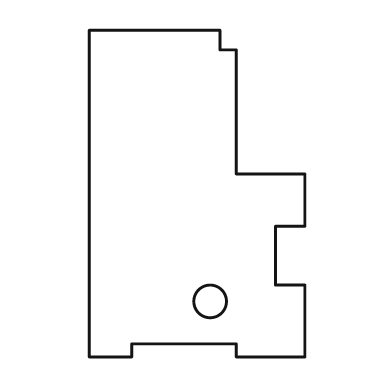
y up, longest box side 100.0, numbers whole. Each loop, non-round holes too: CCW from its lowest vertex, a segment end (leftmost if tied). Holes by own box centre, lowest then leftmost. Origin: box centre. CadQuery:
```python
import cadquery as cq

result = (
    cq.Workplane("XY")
    .moveTo(-33.0, -50.0)
    .lineTo(-20.0, -50.0)
    .lineTo(-20.0, -46.0)
    .lineTo(12.0, -46.0)
    .lineTo(12.0, -50.0)
    .lineTo(33.0, -50.0)
    .lineTo(33.0, -28.0)
    .lineTo(24.0, -28.0)
    .lineTo(24.0, -10.0)
    .lineTo(33.0, -10.0)
    .lineTo(33.0, 6.0)
    .lineTo(12.0, 6.0)
    .lineTo(12.0, 44.0)
    .lineTo(7.0, 44.0)
    .lineTo(7.0, 50.0)
    .lineTo(-33.0, 50.0)
    .close()
    .moveTo(4.0, -33.0)
    .circle(5.0)
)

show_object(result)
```